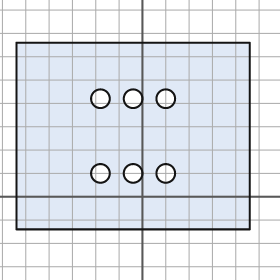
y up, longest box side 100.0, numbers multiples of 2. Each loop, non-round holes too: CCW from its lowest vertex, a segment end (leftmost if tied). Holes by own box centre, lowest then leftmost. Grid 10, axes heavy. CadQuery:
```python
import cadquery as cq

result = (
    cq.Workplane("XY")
    .moveTo(-54.0, -14.0)
    .lineTo(46.0, -14.0)
    .lineTo(46.0, 66.0)
    .lineTo(-54.0, 66.0)
    .close()
    .moveTo(-18.0, 10.0)
    .circle(4.0)
    .moveTo(-4.0, 10.0)
    .circle(4.0)
    .moveTo(10.0, 10.0)
    .circle(4.0)
    .moveTo(-18.0, 42.0)
    .circle(4.0)
    .moveTo(-4.0, 42.0)
    .circle(4.0)
    .moveTo(10.0, 42.0)
    .circle(4.0)
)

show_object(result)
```